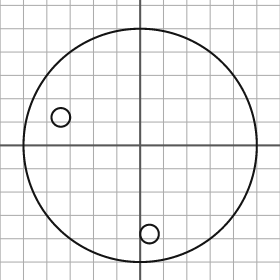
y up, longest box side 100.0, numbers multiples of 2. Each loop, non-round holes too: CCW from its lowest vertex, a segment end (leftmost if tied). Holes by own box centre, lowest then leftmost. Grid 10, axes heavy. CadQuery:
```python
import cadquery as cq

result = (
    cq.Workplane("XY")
    .moveTo(0.0, 0.0)
    .circle(50.0)
    .moveTo(4.0, -38.0)
    .circle(4.0)
    .moveTo(-34.0, 12.0)
    .circle(4.0)
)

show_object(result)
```